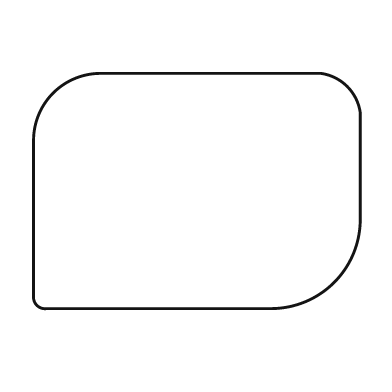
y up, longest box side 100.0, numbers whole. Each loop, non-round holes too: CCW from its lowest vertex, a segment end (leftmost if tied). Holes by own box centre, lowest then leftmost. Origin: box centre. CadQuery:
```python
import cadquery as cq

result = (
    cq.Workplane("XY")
    .moveTo(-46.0, -36.0)
    .lineTo(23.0, -36.0)
    .threePointArc((42.0, -28.0), (50.0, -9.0))
    .lineTo(50.0, 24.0)
    .threePointArc((46.0, 32.0), (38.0, 36.0))
    .lineTo(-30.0, 36.0)
    .threePointArc((-44.0, 30.0), (-50.0, 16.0))
    .lineTo(-50.0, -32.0)
    .threePointArc((-49.0, -35.0), (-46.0, -36.0))
    .close()
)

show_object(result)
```